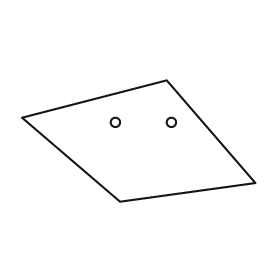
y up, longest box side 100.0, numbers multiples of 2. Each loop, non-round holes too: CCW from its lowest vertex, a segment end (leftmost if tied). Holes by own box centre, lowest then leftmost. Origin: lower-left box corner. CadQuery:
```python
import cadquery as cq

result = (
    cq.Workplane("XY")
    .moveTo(42.0, 0.0)
    .lineTo(100.0, 8.0)
    .lineTo(62.0, 52.0)
    .lineTo(0.0, 36.0)
    .close()
    .moveTo(40.0, 34.0)
    .circle(2.0)
    .moveTo(64.0, 34.0)
    .circle(2.0)
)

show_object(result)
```